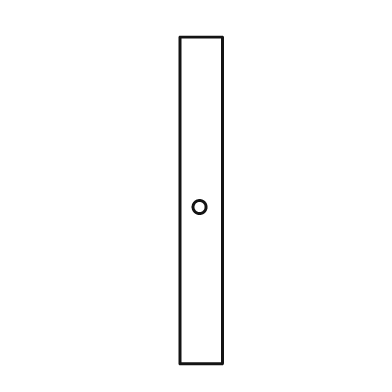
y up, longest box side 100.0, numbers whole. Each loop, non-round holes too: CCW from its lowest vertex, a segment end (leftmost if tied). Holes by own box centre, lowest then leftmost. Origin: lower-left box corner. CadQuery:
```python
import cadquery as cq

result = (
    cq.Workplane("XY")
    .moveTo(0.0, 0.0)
    .lineTo(13.0, 0.0)
    .lineTo(13.0, 100.0)
    .lineTo(0.0, 100.0)
    .close()
    .moveTo(6.0, 48.0)
    .circle(2.0)
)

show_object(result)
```